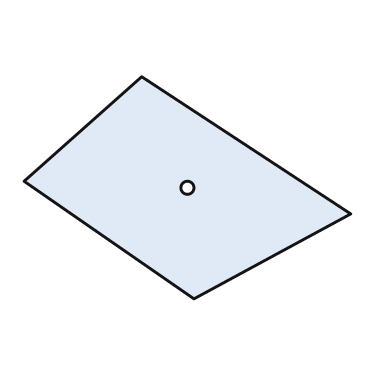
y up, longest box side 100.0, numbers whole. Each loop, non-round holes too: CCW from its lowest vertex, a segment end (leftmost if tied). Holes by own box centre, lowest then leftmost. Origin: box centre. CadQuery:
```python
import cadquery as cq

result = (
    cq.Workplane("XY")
    .moveTo(2.0, -34.0)
    .lineTo(50.0, -8.0)
    .lineTo(-14.0, 34.0)
    .lineTo(-50.0, 2.0)
    .close()
    .moveTo(0.0, 0.0)
    .circle(2.0)
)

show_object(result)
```